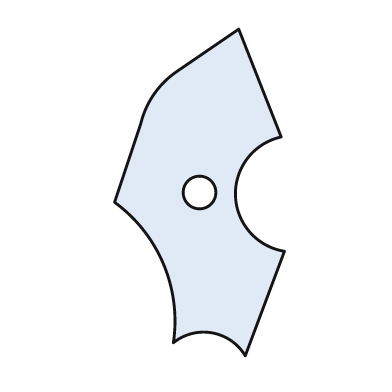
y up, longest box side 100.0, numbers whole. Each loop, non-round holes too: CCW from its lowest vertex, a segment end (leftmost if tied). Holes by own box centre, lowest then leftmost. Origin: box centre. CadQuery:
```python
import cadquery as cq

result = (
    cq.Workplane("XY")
    .moveTo(14.0, -50.0)
    .lineTo(26.0, -18.0)
    .threePointArc((11.0, -1.0), (25.0, 17.0))
    .lineTo(12.0, 50.0)
    .lineTo(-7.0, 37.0)
    .threePointArc((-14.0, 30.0), (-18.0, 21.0))
    .lineTo(-26.0, -3.0)
    .threePointArc((-11.0, -22.0), (-8.0, -46.0))
    .threePointArc((4.0, -43.0), (14.0, -50.0))
    .close()
    .moveTo(0.0, 0.0)
    .circle(5.0)
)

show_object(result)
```